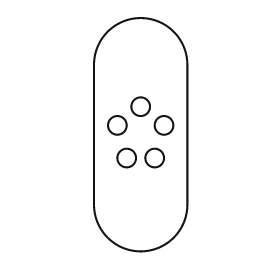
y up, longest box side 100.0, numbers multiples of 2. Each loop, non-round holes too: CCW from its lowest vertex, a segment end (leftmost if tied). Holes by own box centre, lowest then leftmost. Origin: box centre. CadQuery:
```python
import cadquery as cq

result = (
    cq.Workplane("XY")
    .moveTo(-20.0, -30.0)
    .threePointArc((0.0, -50.0), (20.0, -30.0))
    .lineTo(20.0, 30.0)
    .threePointArc((0.0, 50.0), (-20.0, 30.0))
    .close()
    .moveTo(-6.0, -10.0)
    .circle(4.0)
    .moveTo(6.0, -10.0)
    .circle(4.0)
    .moveTo(-10.0, 4.0)
    .circle(4.0)
    .moveTo(10.0, 4.0)
    .circle(4.0)
    .moveTo(0.0, 12.0)
    .circle(4.0)
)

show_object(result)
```